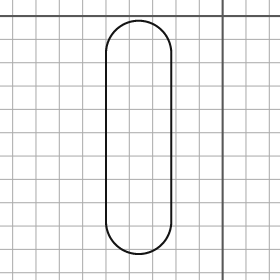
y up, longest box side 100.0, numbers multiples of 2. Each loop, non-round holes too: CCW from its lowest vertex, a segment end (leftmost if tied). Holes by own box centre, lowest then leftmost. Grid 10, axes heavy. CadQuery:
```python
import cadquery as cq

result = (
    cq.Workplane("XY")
    .moveTo(-50.0, -88.0)
    .threePointArc((-36.0, -102.0), (-22.0, -88.0))
    .lineTo(-22.0, -16.0)
    .threePointArc((-36.0, -2.0), (-50.0, -16.0))
    .close()
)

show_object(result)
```